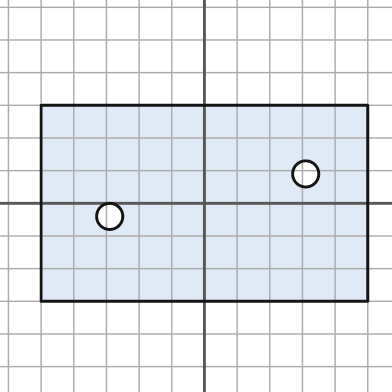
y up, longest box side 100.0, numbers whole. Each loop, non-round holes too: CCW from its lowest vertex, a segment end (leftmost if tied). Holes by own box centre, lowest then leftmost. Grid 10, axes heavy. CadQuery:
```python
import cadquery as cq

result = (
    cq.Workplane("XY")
    .moveTo(-50.0, -30.0)
    .lineTo(50.0, -30.0)
    .lineTo(50.0, 30.0)
    .lineTo(-50.0, 30.0)
    .close()
    .moveTo(-29.0, -4.0)
    .circle(4.0)
    .moveTo(31.0, 9.0)
    .circle(4.0)
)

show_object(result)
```